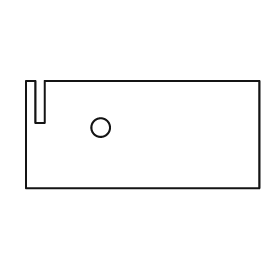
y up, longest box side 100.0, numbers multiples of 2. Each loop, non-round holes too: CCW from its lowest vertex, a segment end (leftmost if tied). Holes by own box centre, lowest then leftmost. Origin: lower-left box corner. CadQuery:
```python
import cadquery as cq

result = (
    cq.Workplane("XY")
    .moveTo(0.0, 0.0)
    .lineTo(100.0, 0.0)
    .lineTo(100.0, 46.0)
    .lineTo(8.0, 46.0)
    .lineTo(8.0, 28.0)
    .lineTo(4.0, 28.0)
    .lineTo(4.0, 46.0)
    .lineTo(0.0, 46.0)
    .close()
    .moveTo(32.0, 26.0)
    .circle(4.0)
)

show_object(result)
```